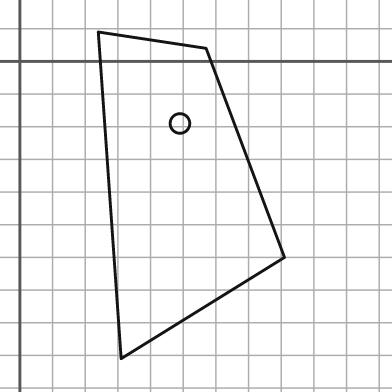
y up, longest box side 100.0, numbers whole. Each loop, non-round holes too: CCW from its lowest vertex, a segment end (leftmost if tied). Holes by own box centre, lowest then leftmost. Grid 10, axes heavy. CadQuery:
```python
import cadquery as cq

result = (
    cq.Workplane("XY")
    .moveTo(31.0, -91.0)
    .lineTo(81.0, -60.0)
    .lineTo(57.0, 4.0)
    .lineTo(24.0, 9.0)
    .close()
    .moveTo(49.0, -19.0)
    .circle(3.0)
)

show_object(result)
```